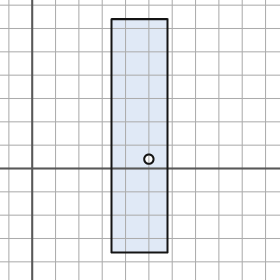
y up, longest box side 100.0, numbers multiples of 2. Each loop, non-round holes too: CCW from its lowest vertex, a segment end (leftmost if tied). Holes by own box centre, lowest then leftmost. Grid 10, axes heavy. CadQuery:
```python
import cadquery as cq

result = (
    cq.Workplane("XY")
    .moveTo(34.0, -36.0)
    .lineTo(58.0, -36.0)
    .lineTo(58.0, 64.0)
    .lineTo(34.0, 64.0)
    .close()
    .moveTo(50.0, 4.0)
    .circle(2.0)
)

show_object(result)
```